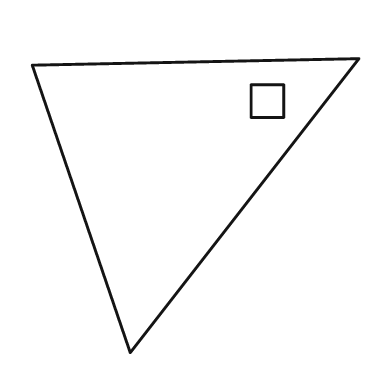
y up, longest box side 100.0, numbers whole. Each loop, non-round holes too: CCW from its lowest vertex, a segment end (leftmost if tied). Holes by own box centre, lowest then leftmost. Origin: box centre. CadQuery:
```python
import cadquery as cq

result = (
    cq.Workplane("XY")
    .moveTo(-20.0, -45.0)
    .lineTo(50.0, 45.0)
    .lineTo(-50.0, 43.0)
    .close()
    .moveTo(17.0, 27.0)
    .lineTo(27.0, 27.0)
    .lineTo(27.0, 37.0)
    .lineTo(17.0, 37.0)
    .close()
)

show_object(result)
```